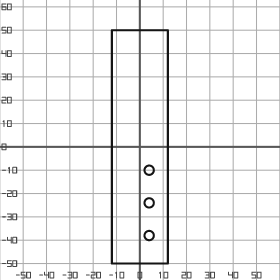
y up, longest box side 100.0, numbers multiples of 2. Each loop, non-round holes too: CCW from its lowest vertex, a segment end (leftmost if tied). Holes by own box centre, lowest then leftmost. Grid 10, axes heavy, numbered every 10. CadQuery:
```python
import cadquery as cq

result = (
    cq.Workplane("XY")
    .moveTo(-12.0, -50.0)
    .lineTo(12.0, -50.0)
    .lineTo(12.0, 50.0)
    .lineTo(-12.0, 50.0)
    .close()
    .moveTo(4.0, -38.0)
    .circle(2.0)
    .moveTo(4.0, -24.0)
    .circle(2.0)
    .moveTo(4.0, -10.0)
    .circle(2.0)
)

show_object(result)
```